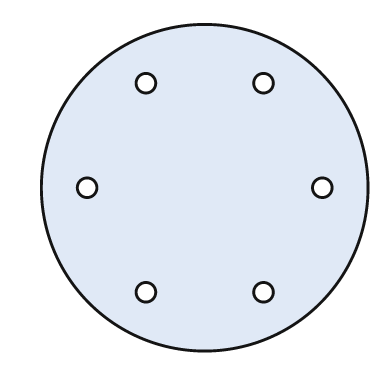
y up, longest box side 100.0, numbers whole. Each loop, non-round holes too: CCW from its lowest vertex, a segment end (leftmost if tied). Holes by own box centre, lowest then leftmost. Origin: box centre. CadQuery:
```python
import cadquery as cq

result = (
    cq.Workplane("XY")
    .moveTo(0.0, 0.0)
    .circle(50.0)
    .moveTo(-18.0, -32.0)
    .circle(3.0)
    .moveTo(18.0, -32.0)
    .circle(3.0)
    .moveTo(-36.0, 0.0)
    .circle(3.0)
    .moveTo(36.0, 0.0)
    .circle(3.0)
    .moveTo(-18.0, 32.0)
    .circle(3.0)
    .moveTo(18.0, 32.0)
    .circle(3.0)
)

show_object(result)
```